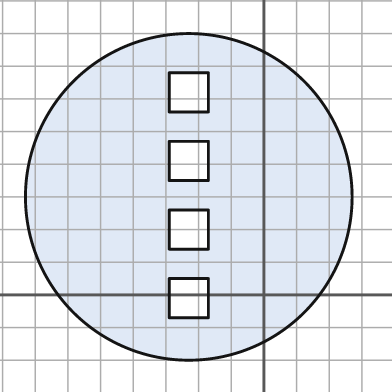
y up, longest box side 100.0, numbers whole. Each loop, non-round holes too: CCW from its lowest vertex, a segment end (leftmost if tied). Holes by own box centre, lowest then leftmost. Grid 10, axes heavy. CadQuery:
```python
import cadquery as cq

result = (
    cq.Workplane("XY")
    .moveTo(-23.0, 30.0)
    .circle(50.0)
    .moveTo(-29.0, -7.0)
    .lineTo(-17.0, -7.0)
    .lineTo(-17.0, 5.0)
    .lineTo(-29.0, 5.0)
    .close()
    .moveTo(-29.0, 14.0)
    .lineTo(-17.0, 14.0)
    .lineTo(-17.0, 26.0)
    .lineTo(-29.0, 26.0)
    .close()
    .moveTo(-29.0, 35.0)
    .lineTo(-17.0, 35.0)
    .lineTo(-17.0, 47.0)
    .lineTo(-29.0, 47.0)
    .close()
    .moveTo(-29.0, 56.0)
    .lineTo(-17.0, 56.0)
    .lineTo(-17.0, 68.0)
    .lineTo(-29.0, 68.0)
    .close()
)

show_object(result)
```